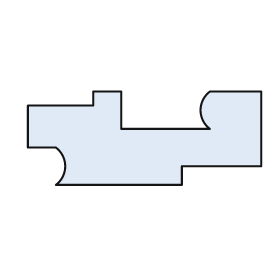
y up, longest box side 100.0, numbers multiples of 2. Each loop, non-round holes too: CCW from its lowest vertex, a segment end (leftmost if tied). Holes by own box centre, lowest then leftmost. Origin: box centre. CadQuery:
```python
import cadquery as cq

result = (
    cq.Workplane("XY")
    .moveTo(-38.0, -20.0)
    .lineTo(16.0, -20.0)
    .lineTo(16.0, -12.0)
    .lineTo(50.0, -12.0)
    .lineTo(50.0, 20.0)
    .lineTo(28.0, 20.0)
    .threePointArc((24.0, 12.0), (28.0, 4.0))
    .lineTo(-10.0, 4.0)
    .lineTo(-10.0, 20.0)
    .lineTo(-22.0, 20.0)
    .lineTo(-22.0, 14.0)
    .lineTo(-50.0, 14.0)
    .lineTo(-50.0, -4.0)
    .lineTo(-38.0, -4.0)
    .threePointArc((-34.0, -12.0), (-38.0, -20.0))
    .close()
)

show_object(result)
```